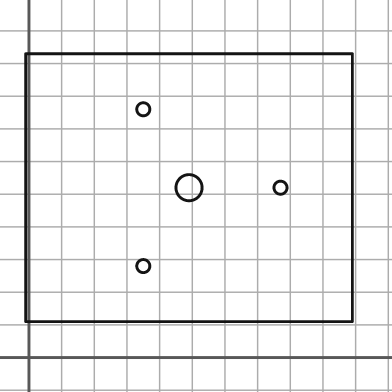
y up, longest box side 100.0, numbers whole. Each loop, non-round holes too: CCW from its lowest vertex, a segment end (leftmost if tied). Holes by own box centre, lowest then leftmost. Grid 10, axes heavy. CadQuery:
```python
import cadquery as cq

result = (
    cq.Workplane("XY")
    .moveTo(-1.0, 11.0)
    .lineTo(99.0, 11.0)
    .lineTo(99.0, 93.0)
    .lineTo(-1.0, 93.0)
    .close()
    .moveTo(35.0, 28.0)
    .circle(2.0)
    .moveTo(49.0, 52.0)
    .circle(4.0)
    .moveTo(77.0, 52.0)
    .circle(2.0)
    .moveTo(35.0, 76.0)
    .circle(2.0)
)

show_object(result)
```